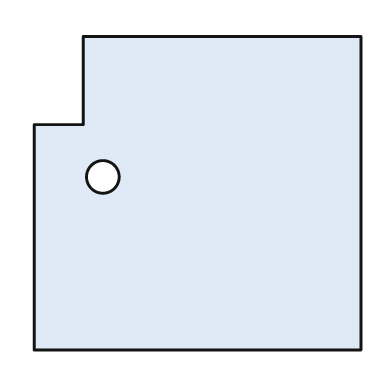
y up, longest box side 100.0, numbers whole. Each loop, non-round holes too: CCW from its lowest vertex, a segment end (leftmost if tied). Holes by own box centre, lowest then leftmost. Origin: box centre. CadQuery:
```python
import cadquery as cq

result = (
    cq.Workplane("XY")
    .moveTo(-50.0, -48.0)
    .lineTo(50.0, -48.0)
    .lineTo(50.0, 48.0)
    .lineTo(-35.0, 48.0)
    .lineTo(-35.0, 21.0)
    .lineTo(-50.0, 21.0)
    .close()
    .moveTo(-29.0, 5.0)
    .circle(5.0)
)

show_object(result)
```